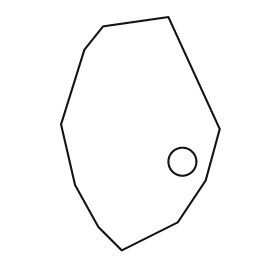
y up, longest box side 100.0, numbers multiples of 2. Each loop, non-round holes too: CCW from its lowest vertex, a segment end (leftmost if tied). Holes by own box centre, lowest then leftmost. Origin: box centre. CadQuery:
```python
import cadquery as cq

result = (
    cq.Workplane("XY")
    .moveTo(-8.0, -50.0)
    .lineTo(16.0, -38.0)
    .lineTo(28.0, -20.0)
    .lineTo(34.0, 2.0)
    .lineTo(12.0, 50.0)
    .lineTo(-16.0, 46.0)
    .lineTo(-24.0, 36.0)
    .lineTo(-34.0, 4.0)
    .lineTo(-28.0, -22.0)
    .lineTo(-18.0, -40.0)
    .close()
    .moveTo(18.0, -12.0)
    .circle(6.0)
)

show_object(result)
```